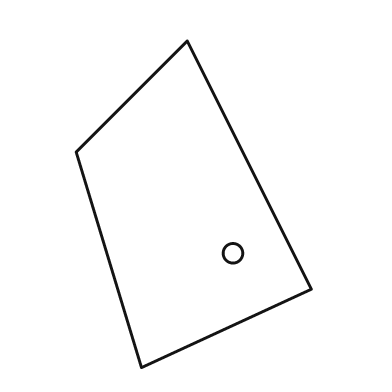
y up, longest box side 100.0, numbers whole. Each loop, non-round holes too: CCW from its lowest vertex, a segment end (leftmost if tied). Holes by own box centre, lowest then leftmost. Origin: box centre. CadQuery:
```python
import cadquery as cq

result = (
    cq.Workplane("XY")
    .moveTo(-16.0, -50.0)
    .lineTo(36.0, -26.0)
    .lineTo(-2.0, 50.0)
    .lineTo(-36.0, 16.0)
    .close()
    .moveTo(12.0, -15.0)
    .circle(3.0)
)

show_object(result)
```